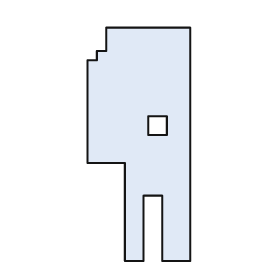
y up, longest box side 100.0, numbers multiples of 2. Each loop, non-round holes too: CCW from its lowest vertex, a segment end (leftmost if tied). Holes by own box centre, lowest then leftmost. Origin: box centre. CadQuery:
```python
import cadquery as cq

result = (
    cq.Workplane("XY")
    .moveTo(-6.0, -50.0)
    .lineTo(2.0, -50.0)
    .lineTo(2.0, -22.0)
    .lineTo(10.0, -22.0)
    .lineTo(10.0, -50.0)
    .lineTo(22.0, -50.0)
    .lineTo(22.0, 50.0)
    .lineTo(-14.0, 50.0)
    .lineTo(-14.0, 40.0)
    .lineTo(-18.0, 40.0)
    .lineTo(-18.0, 36.0)
    .lineTo(-22.0, 36.0)
    .lineTo(-22.0, -8.0)
    .lineTo(-6.0, -8.0)
    .close()
    .moveTo(4.0, 4.0)
    .lineTo(12.0, 4.0)
    .lineTo(12.0, 12.0)
    .lineTo(4.0, 12.0)
    .close()
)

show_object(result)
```